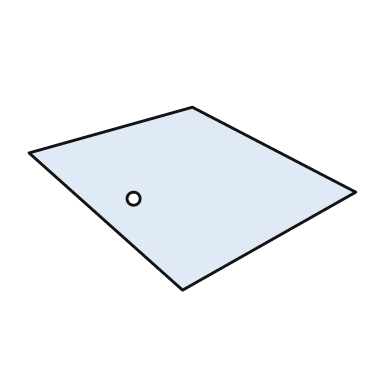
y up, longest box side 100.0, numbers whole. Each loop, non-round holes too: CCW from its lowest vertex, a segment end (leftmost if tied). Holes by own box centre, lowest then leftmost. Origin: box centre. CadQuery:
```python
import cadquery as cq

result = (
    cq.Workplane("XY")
    .moveTo(-3.0, -28.0)
    .lineTo(50.0, 2.0)
    .lineTo(0.0, 28.0)
    .lineTo(-50.0, 14.0)
    .close()
    .moveTo(-18.0, 0.0)
    .circle(2.0)
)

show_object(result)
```